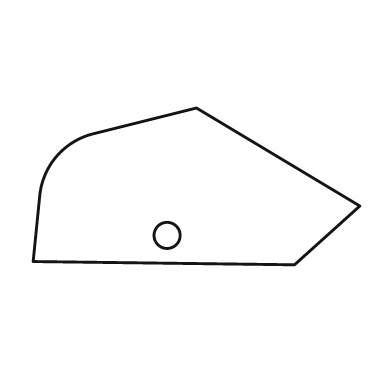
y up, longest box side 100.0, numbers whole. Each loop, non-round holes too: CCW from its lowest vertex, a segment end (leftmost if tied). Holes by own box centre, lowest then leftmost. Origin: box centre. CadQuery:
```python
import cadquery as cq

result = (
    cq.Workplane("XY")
    .moveTo(30.0, -24.0)
    .lineTo(50.0, -6.0)
    .lineTo(0.0, 24.0)
    .lineTo(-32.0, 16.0)
    .threePointArc((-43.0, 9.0), (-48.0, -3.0))
    .lineTo(-50.0, -23.0)
    .close()
    .moveTo(-9.0, -15.0)
    .circle(4.0)
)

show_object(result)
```